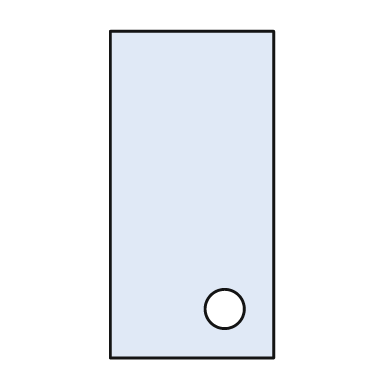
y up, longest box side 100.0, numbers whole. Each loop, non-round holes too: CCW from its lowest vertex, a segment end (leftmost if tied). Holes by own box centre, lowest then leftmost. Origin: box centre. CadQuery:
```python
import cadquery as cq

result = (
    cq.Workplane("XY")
    .moveTo(-25.0, -50.0)
    .lineTo(25.0, -50.0)
    .lineTo(25.0, 50.0)
    .lineTo(-25.0, 50.0)
    .close()
    .moveTo(10.0, -35.0)
    .circle(6.0)
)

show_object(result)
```